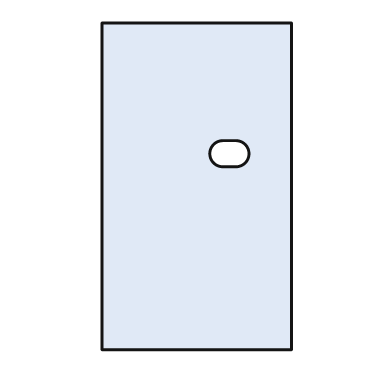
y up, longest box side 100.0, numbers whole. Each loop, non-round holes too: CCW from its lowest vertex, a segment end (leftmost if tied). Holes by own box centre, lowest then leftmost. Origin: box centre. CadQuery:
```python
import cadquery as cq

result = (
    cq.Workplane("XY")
    .moveTo(-29.0, -50.0)
    .lineTo(29.0, -50.0)
    .lineTo(29.0, 50.0)
    .lineTo(-29.0, 50.0)
    .close()
    .moveTo(8.0, 6.0)
    .lineTo(12.0, 6.0)
    .threePointArc((16.0, 10.0), (12.0, 14.0))
    .lineTo(8.0, 14.0)
    .threePointArc((4.0, 10.0), (8.0, 6.0))
    .close()
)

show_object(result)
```